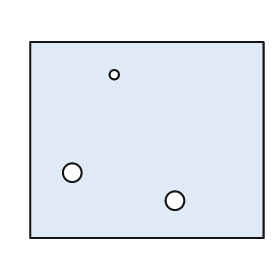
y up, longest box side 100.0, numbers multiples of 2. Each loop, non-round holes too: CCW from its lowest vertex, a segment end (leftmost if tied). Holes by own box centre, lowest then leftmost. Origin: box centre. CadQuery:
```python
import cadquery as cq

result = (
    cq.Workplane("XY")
    .moveTo(-50.0, -42.0)
    .lineTo(50.0, -42.0)
    .lineTo(50.0, 42.0)
    .lineTo(-50.0, 42.0)
    .close()
    .moveTo(12.0, -26.0)
    .circle(4.0)
    .moveTo(-32.0, -14.0)
    .circle(4.0)
    .moveTo(-14.0, 28.0)
    .circle(2.0)
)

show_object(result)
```